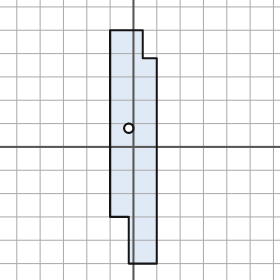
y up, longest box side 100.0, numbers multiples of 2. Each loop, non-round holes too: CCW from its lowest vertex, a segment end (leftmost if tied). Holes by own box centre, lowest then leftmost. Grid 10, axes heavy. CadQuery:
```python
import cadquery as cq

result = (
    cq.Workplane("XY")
    .moveTo(-2.0, -50.0)
    .lineTo(10.0, -50.0)
    .lineTo(10.0, 38.0)
    .lineTo(4.0, 38.0)
    .lineTo(4.0, 50.0)
    .lineTo(-10.0, 50.0)
    .lineTo(-10.0, -30.0)
    .lineTo(-2.0, -30.0)
    .close()
    .moveTo(-2.0, 8.0)
    .circle(2.0)
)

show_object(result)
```